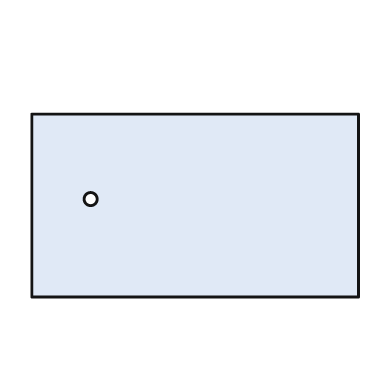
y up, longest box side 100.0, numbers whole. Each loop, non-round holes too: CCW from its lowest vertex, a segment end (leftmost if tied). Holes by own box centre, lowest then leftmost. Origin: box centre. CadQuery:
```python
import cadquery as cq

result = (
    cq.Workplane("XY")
    .moveTo(-50.0, -28.0)
    .lineTo(50.0, -28.0)
    .lineTo(50.0, 28.0)
    .lineTo(-50.0, 28.0)
    .close()
    .moveTo(-32.0, 2.0)
    .circle(2.0)
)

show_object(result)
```